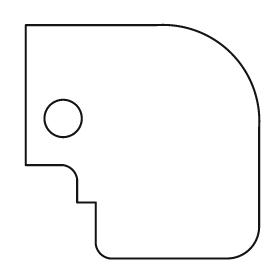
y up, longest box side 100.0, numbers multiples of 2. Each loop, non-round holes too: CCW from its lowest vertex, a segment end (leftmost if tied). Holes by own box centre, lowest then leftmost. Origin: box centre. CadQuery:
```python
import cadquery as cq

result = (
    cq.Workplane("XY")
    .moveTo(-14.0, -50.0)
    .lineTo(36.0, -50.0)
    .threePointArc((46.0, -46.0), (50.0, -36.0))
    .lineTo(50.0, 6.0)
    .threePointArc((38.0, 38.0), (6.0, 50.0))
    .lineTo(-50.0, 50.0)
    .lineTo(-50.0, -10.0)
    .lineTo(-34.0, -10.0)
    .threePointArc((-30.0, -12.0), (-28.0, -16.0))
    .lineTo(-28.0, -26.0)
    .lineTo(-20.0, -26.0)
    .lineTo(-20.0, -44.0)
    .threePointArc((-18.0, -48.0), (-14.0, -50.0))
    .close()
    .moveTo(-34.0, 10.0)
    .circle(8.0)
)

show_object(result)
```